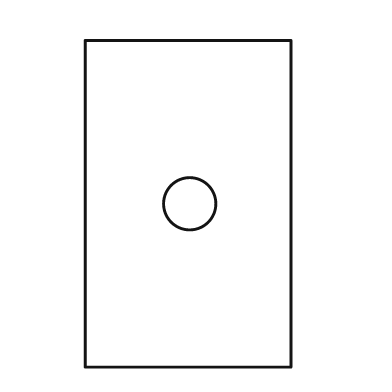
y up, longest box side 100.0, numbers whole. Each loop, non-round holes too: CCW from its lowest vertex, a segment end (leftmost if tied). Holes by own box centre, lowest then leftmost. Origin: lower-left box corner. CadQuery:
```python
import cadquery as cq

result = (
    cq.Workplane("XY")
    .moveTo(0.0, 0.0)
    .lineTo(63.0, 0.0)
    .lineTo(63.0, 100.0)
    .lineTo(0.0, 100.0)
    .close()
    .moveTo(32.0, 50.0)
    .circle(8.0)
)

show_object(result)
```